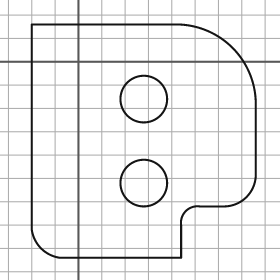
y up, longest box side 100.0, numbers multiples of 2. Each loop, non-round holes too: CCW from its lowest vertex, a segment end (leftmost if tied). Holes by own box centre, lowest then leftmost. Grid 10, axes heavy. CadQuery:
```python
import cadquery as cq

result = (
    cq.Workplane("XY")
    .moveTo(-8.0, -84.0)
    .lineTo(44.0, -84.0)
    .lineTo(44.0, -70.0)
    .threePointArc((46.0, -64.0), (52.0, -62.0))
    .lineTo(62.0, -62.0)
    .threePointArc((72.0, -58.0), (76.0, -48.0))
    .lineTo(76.0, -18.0)
    .threePointArc((66.0, 6.0), (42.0, 16.0))
    .lineTo(-20.0, 16.0)
    .lineTo(-20.0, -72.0)
    .threePointArc((-16.0, -80.0), (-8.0, -84.0))
    .close()
    .moveTo(28.0, -52.0)
    .circle(10.0)
    .moveTo(28.0, -16.0)
    .circle(10.0)
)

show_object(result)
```